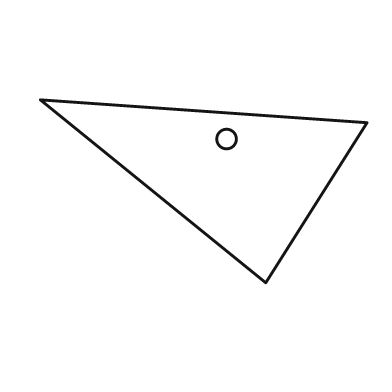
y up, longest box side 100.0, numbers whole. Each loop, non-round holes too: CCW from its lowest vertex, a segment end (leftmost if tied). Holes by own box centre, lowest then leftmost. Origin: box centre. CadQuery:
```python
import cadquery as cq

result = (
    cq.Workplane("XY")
    .moveTo(19.0, -28.0)
    .lineTo(50.0, 21.0)
    .lineTo(-50.0, 28.0)
    .close()
    .moveTo(7.0, 16.0)
    .circle(3.0)
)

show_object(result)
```